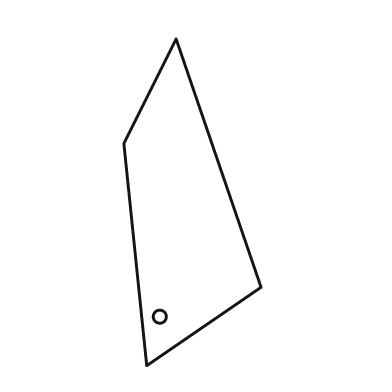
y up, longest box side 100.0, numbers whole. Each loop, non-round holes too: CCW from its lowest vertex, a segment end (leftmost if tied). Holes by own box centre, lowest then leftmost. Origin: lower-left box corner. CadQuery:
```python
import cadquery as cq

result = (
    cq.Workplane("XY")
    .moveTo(7.0, 0.0)
    .lineTo(42.0, 24.0)
    .lineTo(16.0, 100.0)
    .lineTo(0.0, 68.0)
    .close()
    .moveTo(11.0, 15.0)
    .circle(2.0)
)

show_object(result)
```